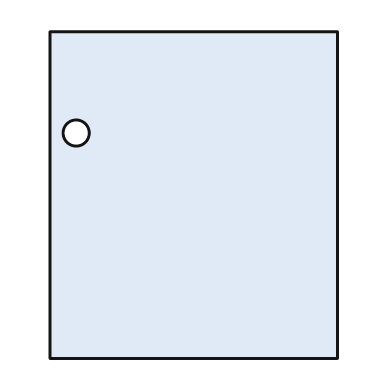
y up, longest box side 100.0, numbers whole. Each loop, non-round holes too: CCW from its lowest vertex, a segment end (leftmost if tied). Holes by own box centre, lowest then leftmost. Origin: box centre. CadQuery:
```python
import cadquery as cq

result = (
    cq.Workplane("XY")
    .moveTo(-44.0, -50.0)
    .lineTo(44.0, -50.0)
    .lineTo(44.0, 50.0)
    .lineTo(-44.0, 50.0)
    .close()
    .moveTo(-36.0, 19.0)
    .circle(4.0)
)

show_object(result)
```